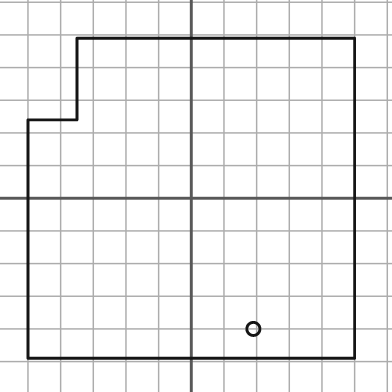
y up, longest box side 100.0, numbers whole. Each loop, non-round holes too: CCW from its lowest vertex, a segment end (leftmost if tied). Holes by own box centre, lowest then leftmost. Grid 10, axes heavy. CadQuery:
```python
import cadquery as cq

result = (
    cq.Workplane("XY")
    .moveTo(-50.0, -49.0)
    .lineTo(50.0, -49.0)
    .lineTo(50.0, 49.0)
    .lineTo(-35.0, 49.0)
    .lineTo(-35.0, 24.0)
    .lineTo(-50.0, 24.0)
    .close()
    .moveTo(19.0, -40.0)
    .circle(2.0)
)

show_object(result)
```